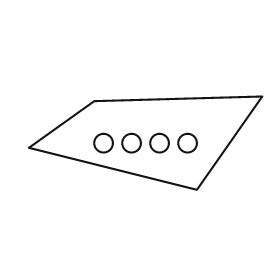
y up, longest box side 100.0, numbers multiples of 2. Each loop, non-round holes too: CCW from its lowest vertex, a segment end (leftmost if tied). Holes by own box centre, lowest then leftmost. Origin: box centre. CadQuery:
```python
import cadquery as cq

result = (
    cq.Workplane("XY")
    .moveTo(22.0, -20.0)
    .lineTo(50.0, 20.0)
    .lineTo(-22.0, 18.0)
    .lineTo(-50.0, -2.0)
    .close()
    .moveTo(-18.0, 0.0)
    .circle(4.0)
    .moveTo(-6.0, 0.0)
    .circle(4.0)
    .moveTo(6.0, 0.0)
    .circle(4.0)
    .moveTo(18.0, 0.0)
    .circle(4.0)
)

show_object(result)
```